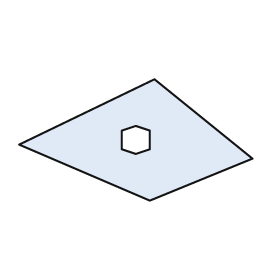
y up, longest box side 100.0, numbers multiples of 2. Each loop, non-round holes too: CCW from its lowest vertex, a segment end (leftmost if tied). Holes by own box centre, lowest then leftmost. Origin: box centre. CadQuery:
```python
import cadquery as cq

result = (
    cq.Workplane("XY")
    .moveTo(6.0, -26.0)
    .lineTo(50.0, -8.0)
    .lineTo(8.0, 26.0)
    .lineTo(-50.0, -2.0)
    .close()
    .moveTo(0.0, -6.0)
    .lineTo(6.0, -4.0)
    .lineTo(6.0, 4.0)
    .lineTo(0.0, 6.0)
    .lineTo(-6.0, 4.0)
    .lineTo(-6.0, -4.0)
    .close()
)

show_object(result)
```